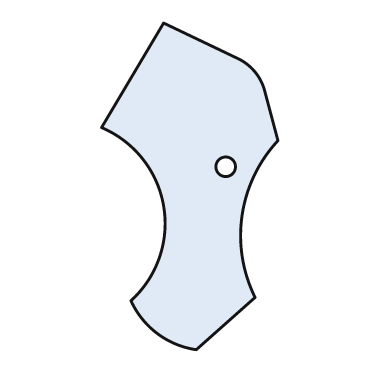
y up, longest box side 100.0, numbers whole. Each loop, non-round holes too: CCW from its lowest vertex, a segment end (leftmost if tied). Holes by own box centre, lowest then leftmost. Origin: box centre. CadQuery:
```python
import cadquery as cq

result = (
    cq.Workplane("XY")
    .moveTo(2.0, -50.0)
    .lineTo(20.0, -34.0)
    .threePointArc((16.0, -9.0), (27.0, 14.0))
    .lineTo(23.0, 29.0)
    .threePointArc((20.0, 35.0), (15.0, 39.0))
    .lineTo(-8.0, 50.0)
    .lineTo(-27.0, 18.0)
    .threePointArc((-8.0, -6.0), (-18.0, -35.0))
    .threePointArc((-10.0, -45.0), (2.0, -50.0))
    .close()
    .moveTo(11.0, 6.0)
    .circle(3.0)
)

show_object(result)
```